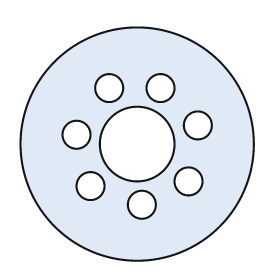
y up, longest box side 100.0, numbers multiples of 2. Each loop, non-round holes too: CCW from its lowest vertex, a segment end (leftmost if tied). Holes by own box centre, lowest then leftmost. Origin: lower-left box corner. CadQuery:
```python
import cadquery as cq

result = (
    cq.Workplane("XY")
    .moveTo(50.0, 50.0)
    .circle(50.0)
    .moveTo(52.0, 24.0)
    .circle(6.0)
    .moveTo(30.0, 32.0)
    .circle(6.0)
    .moveTo(72.0, 34.0)
    .circle(6.0)
    .moveTo(50.0, 50.0)
    .circle(16.0)
    .moveTo(24.0, 54.0)
    .circle(6.0)
    .moveTo(76.0, 58.0)
    .circle(6.0)
    .moveTo(38.0, 74.0)
    .circle(6.0)
    .moveTo(60.0, 74.0)
    .circle(6.0)
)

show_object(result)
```